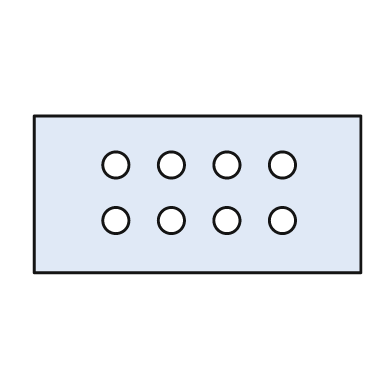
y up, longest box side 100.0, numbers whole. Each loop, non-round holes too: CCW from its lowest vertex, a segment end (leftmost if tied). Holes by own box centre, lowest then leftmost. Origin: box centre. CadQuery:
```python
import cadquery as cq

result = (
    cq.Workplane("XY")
    .moveTo(-50.0, -24.0)
    .lineTo(50.0, -24.0)
    .lineTo(50.0, 24.0)
    .lineTo(-50.0, 24.0)
    .close()
    .moveTo(-25.0, -8.0)
    .circle(4.0)
    .moveTo(-8.0, -8.0)
    .circle(4.0)
    .moveTo(9.0, -8.0)
    .circle(4.0)
    .moveTo(26.0, -8.0)
    .circle(4.0)
    .moveTo(-25.0, 9.0)
    .circle(4.0)
    .moveTo(-8.0, 9.0)
    .circle(4.0)
    .moveTo(9.0, 9.0)
    .circle(4.0)
    .moveTo(26.0, 9.0)
    .circle(4.0)
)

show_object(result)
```